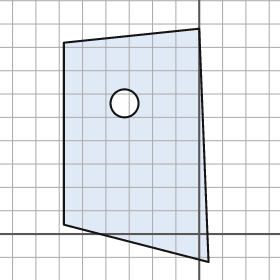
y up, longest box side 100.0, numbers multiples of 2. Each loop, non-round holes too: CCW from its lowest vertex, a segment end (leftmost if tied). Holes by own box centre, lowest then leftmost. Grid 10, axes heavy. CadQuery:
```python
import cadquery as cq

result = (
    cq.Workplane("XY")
    .moveTo(4.0, -12.0)
    .lineTo(0.0, 88.0)
    .lineTo(-58.0, 82.0)
    .lineTo(-58.0, 4.0)
    .close()
    .moveTo(-32.0, 56.0)
    .circle(6.0)
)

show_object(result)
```